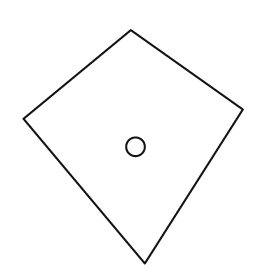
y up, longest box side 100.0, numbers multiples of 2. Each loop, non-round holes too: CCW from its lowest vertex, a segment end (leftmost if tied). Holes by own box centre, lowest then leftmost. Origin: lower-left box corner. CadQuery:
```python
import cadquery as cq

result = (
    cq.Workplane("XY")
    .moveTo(52.0, 0.0)
    .lineTo(94.0, 66.0)
    .lineTo(46.0, 100.0)
    .lineTo(0.0, 62.0)
    .close()
    .moveTo(48.0, 50.0)
    .circle(4.0)
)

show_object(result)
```